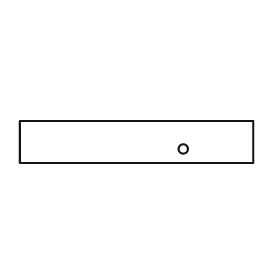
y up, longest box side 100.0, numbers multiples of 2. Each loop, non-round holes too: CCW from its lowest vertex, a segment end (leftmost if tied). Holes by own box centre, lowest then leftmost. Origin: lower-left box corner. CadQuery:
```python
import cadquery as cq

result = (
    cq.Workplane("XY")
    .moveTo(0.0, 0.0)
    .lineTo(100.0, 0.0)
    .lineTo(100.0, 18.0)
    .lineTo(0.0, 18.0)
    .close()
    .moveTo(70.0, 6.0)
    .circle(2.0)
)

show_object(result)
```